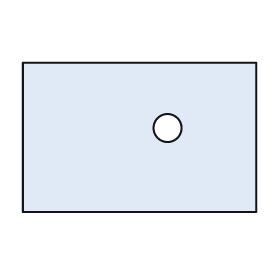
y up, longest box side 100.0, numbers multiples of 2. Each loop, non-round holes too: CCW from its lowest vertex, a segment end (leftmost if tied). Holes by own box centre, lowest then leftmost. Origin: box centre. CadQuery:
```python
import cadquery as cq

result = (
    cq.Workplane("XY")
    .moveTo(-50.0, -32.0)
    .lineTo(50.0, -32.0)
    .lineTo(50.0, 32.0)
    .lineTo(-50.0, 32.0)
    .close()
    .moveTo(12.0, 4.0)
    .circle(6.0)
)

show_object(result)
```